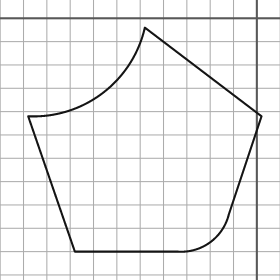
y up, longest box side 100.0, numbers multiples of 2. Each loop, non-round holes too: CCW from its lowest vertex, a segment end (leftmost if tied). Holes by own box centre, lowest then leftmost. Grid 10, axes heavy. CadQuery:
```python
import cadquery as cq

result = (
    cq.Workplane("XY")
    .moveTo(-78.0, -100.0)
    .lineTo(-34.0, -100.0)
    .threePointArc((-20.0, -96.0), (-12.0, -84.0))
    .lineTo(2.0, -42.0)
    .lineTo(-48.0, -4.0)
    .threePointArc((-66.0, -32.0), (-98.0, -42.0))
    .close()
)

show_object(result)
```